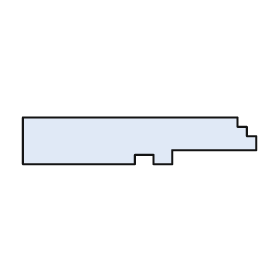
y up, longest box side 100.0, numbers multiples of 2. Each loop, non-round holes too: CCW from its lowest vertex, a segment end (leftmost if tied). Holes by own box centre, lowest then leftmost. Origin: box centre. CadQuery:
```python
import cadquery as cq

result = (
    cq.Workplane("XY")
    .moveTo(-50.0, -10.0)
    .lineTo(-2.0, -10.0)
    .lineTo(-2.0, -6.0)
    .lineTo(6.0, -6.0)
    .lineTo(6.0, -10.0)
    .lineTo(14.0, -10.0)
    .lineTo(14.0, -4.0)
    .lineTo(50.0, -4.0)
    .lineTo(50.0, 2.0)
    .lineTo(46.0, 2.0)
    .lineTo(46.0, 6.0)
    .lineTo(42.0, 6.0)
    .lineTo(42.0, 10.0)
    .lineTo(-50.0, 10.0)
    .close()
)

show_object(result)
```